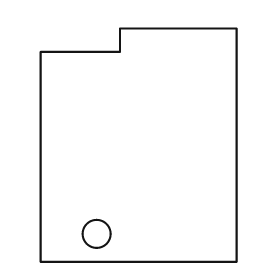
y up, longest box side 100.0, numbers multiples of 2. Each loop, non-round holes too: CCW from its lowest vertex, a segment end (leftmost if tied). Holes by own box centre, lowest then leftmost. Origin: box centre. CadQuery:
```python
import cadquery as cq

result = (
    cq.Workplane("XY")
    .moveTo(-42.0, -50.0)
    .lineTo(42.0, -50.0)
    .lineTo(42.0, 50.0)
    .lineTo(-8.0, 50.0)
    .lineTo(-8.0, 40.0)
    .lineTo(-42.0, 40.0)
    .close()
    .moveTo(-18.0, -38.0)
    .circle(6.0)
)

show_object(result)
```